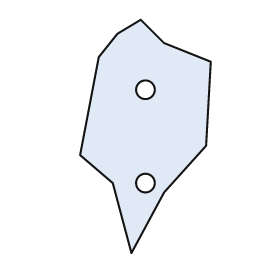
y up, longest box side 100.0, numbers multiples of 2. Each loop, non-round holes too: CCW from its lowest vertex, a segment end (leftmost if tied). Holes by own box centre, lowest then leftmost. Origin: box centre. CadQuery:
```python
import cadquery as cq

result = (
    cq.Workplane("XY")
    .moveTo(-6.0, -50.0)
    .lineTo(8.0, -24.0)
    .lineTo(26.0, -4.0)
    .lineTo(28.0, 32.0)
    .lineTo(8.0, 40.0)
    .lineTo(-2.0, 50.0)
    .lineTo(-12.0, 44.0)
    .lineTo(-20.0, 34.0)
    .lineTo(-28.0, -8.0)
    .lineTo(-14.0, -20.0)
    .close()
    .moveTo(0.0, -20.0)
    .circle(4.0)
    .moveTo(0.0, 20.0)
    .circle(4.0)
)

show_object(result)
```